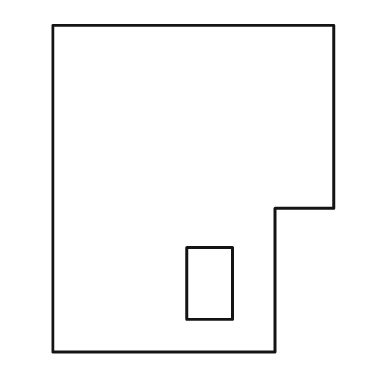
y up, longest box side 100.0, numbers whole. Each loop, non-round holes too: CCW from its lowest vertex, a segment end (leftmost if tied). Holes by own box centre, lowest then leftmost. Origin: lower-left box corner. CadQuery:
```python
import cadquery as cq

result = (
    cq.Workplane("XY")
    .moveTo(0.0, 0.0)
    .lineTo(68.0, 0.0)
    .lineTo(68.0, 44.0)
    .lineTo(86.0, 44.0)
    .lineTo(86.0, 100.0)
    .lineTo(0.0, 100.0)
    .close()
    .moveTo(41.0, 10.0)
    .lineTo(55.0, 10.0)
    .lineTo(55.0, 32.0)
    .lineTo(41.0, 32.0)
    .close()
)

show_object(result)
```